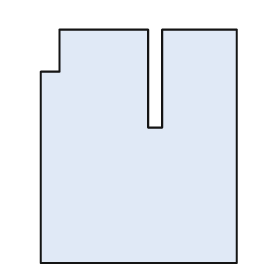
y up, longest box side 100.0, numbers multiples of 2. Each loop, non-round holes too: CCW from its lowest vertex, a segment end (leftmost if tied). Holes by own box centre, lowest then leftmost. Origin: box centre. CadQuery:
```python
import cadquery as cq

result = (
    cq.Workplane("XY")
    .moveTo(-42.0, -50.0)
    .lineTo(42.0, -50.0)
    .lineTo(42.0, 50.0)
    .lineTo(10.0, 50.0)
    .lineTo(10.0, 8.0)
    .lineTo(4.0, 8.0)
    .lineTo(4.0, 50.0)
    .lineTo(-34.0, 50.0)
    .lineTo(-34.0, 32.0)
    .lineTo(-42.0, 32.0)
    .close()
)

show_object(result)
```